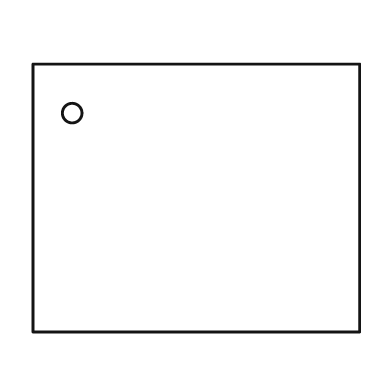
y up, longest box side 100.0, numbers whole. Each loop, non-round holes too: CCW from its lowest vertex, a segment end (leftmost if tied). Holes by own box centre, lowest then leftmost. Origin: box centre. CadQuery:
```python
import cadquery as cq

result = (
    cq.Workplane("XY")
    .moveTo(-50.0, -41.0)
    .lineTo(50.0, -41.0)
    .lineTo(50.0, 41.0)
    .lineTo(-50.0, 41.0)
    .close()
    .moveTo(-38.0, 26.0)
    .circle(3.0)
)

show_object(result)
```